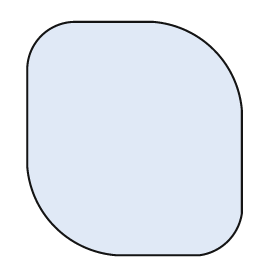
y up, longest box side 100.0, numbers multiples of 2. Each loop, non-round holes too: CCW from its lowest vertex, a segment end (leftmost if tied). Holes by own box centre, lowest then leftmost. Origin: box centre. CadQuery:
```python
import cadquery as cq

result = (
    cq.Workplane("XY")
    .moveTo(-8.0, -50.0)
    .lineTo(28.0, -50.0)
    .threePointArc((40.0, -44.0), (46.0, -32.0))
    .lineTo(46.0, 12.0)
    .threePointArc((34.0, 38.0), (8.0, 50.0))
    .lineTo(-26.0, 50.0)
    .threePointArc((-40.0, 44.0), (-46.0, 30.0))
    .lineTo(-46.0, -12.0)
    .threePointArc((-34.0, -38.0), (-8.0, -50.0))
    .close()
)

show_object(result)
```